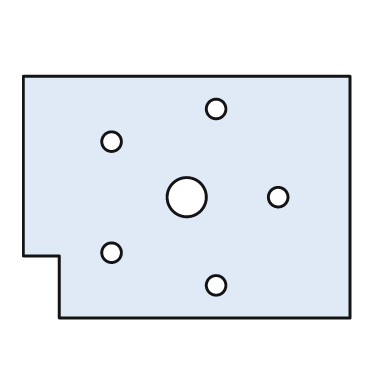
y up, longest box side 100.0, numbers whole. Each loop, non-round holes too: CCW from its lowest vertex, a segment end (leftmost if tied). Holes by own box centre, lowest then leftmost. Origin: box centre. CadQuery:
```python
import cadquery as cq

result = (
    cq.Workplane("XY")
    .moveTo(-39.0, -37.0)
    .lineTo(50.0, -37.0)
    .lineTo(50.0, 37.0)
    .lineTo(-50.0, 37.0)
    .lineTo(-50.0, -18.0)
    .lineTo(-39.0, -18.0)
    .close()
    .moveTo(9.0, -27.0)
    .circle(3.0)
    .moveTo(-23.0, -17.0)
    .circle(3.0)
    .moveTo(0.0, 0.0)
    .circle(6.0)
    .moveTo(28.0, 0.0)
    .circle(3.0)
    .moveTo(-23.0, 17.0)
    .circle(3.0)
    .moveTo(9.0, 27.0)
    .circle(3.0)
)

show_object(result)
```